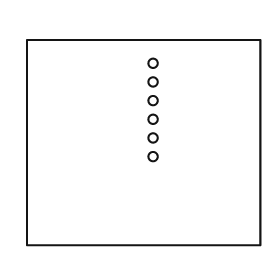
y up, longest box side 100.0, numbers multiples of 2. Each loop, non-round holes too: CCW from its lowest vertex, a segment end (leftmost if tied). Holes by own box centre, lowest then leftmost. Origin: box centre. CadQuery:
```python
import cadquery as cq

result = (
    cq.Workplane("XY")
    .moveTo(-50.0, -44.0)
    .lineTo(50.0, -44.0)
    .lineTo(50.0, 44.0)
    .lineTo(-50.0, 44.0)
    .close()
    .moveTo(4.0, -6.0)
    .circle(2.0)
    .moveTo(4.0, 2.0)
    .circle(2.0)
    .moveTo(4.0, 10.0)
    .circle(2.0)
    .moveTo(4.0, 18.0)
    .circle(2.0)
    .moveTo(4.0, 26.0)
    .circle(2.0)
    .moveTo(4.0, 34.0)
    .circle(2.0)
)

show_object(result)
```